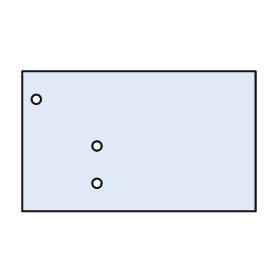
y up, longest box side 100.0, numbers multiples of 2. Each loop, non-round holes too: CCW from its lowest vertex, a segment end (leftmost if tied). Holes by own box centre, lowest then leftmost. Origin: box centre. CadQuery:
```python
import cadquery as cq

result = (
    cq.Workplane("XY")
    .moveTo(-50.0, -30.0)
    .lineTo(50.0, -30.0)
    .lineTo(50.0, 30.0)
    .lineTo(-50.0, 30.0)
    .close()
    .moveTo(-18.0, -18.0)
    .circle(2.0)
    .moveTo(-18.0, -2.0)
    .circle(2.0)
    .moveTo(-44.0, 18.0)
    .circle(2.0)
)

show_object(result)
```